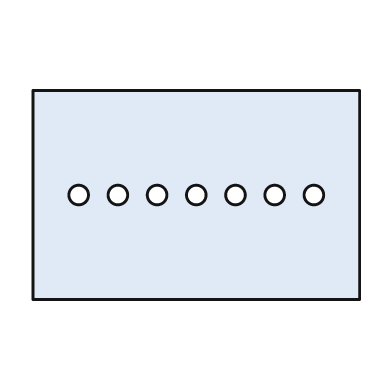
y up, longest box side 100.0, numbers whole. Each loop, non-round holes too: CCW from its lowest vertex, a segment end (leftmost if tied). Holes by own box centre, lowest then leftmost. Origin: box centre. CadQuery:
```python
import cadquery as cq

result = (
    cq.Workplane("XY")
    .moveTo(-50.0, -32.0)
    .lineTo(50.0, -32.0)
    .lineTo(50.0, 32.0)
    .lineTo(-50.0, 32.0)
    .close()
    .moveTo(-36.0, 0.0)
    .circle(3.0)
    .moveTo(-24.0, 0.0)
    .circle(3.0)
    .moveTo(-12.0, 0.0)
    .circle(3.0)
    .moveTo(0.0, 0.0)
    .circle(3.0)
    .moveTo(12.0, 0.0)
    .circle(3.0)
    .moveTo(24.0, 0.0)
    .circle(3.0)
    .moveTo(36.0, 0.0)
    .circle(3.0)
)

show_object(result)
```